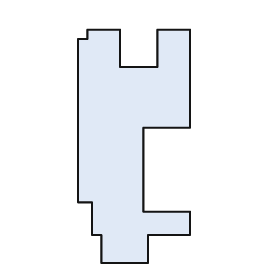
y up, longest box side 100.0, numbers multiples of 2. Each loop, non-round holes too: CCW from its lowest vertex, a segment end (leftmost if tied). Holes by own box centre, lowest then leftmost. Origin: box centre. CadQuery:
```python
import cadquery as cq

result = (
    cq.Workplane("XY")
    .moveTo(-14.0, -50.0)
    .lineTo(6.0, -50.0)
    .lineTo(6.0, -38.0)
    .lineTo(24.0, -38.0)
    .lineTo(24.0, -28.0)
    .lineTo(4.0, -28.0)
    .lineTo(4.0, 8.0)
    .lineTo(24.0, 8.0)
    .lineTo(24.0, 50.0)
    .lineTo(10.0, 50.0)
    .lineTo(10.0, 34.0)
    .lineTo(-6.0, 34.0)
    .lineTo(-6.0, 50.0)
    .lineTo(-20.0, 50.0)
    .lineTo(-20.0, 46.0)
    .lineTo(-24.0, 46.0)
    .lineTo(-24.0, -24.0)
    .lineTo(-18.0, -24.0)
    .lineTo(-18.0, -38.0)
    .lineTo(-14.0, -38.0)
    .close()
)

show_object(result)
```